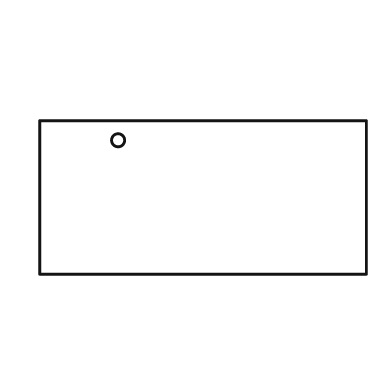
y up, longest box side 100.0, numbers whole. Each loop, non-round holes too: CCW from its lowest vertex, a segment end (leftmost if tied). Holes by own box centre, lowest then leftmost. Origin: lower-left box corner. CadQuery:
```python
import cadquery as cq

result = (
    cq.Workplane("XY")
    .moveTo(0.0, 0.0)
    .lineTo(100.0, 0.0)
    .lineTo(100.0, 47.0)
    .lineTo(0.0, 47.0)
    .close()
    .moveTo(24.0, 41.0)
    .circle(2.0)
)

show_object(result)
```